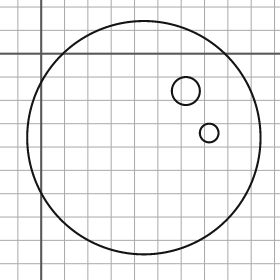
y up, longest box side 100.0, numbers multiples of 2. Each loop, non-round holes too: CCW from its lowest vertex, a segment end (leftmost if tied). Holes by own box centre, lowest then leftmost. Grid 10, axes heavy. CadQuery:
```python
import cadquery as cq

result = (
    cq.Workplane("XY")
    .moveTo(44.0, -36.0)
    .circle(50.0)
    .moveTo(72.0, -34.0)
    .circle(4.0)
    .moveTo(62.0, -16.0)
    .circle(6.0)
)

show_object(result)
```